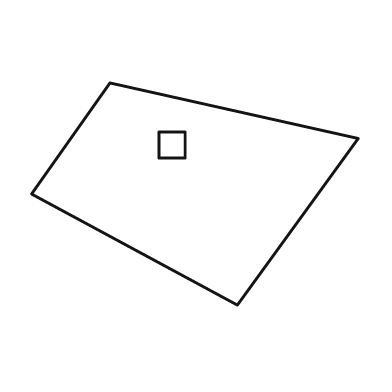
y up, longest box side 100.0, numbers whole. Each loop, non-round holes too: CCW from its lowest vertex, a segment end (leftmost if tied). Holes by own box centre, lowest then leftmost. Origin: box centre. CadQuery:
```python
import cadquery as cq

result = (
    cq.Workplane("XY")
    .moveTo(13.0, -34.0)
    .lineTo(50.0, 17.0)
    .lineTo(-26.0, 34.0)
    .lineTo(-50.0, 0.0)
    .close()
    .moveTo(-11.0, 11.0)
    .lineTo(-3.0, 11.0)
    .lineTo(-3.0, 19.0)
    .lineTo(-11.0, 19.0)
    .close()
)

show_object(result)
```